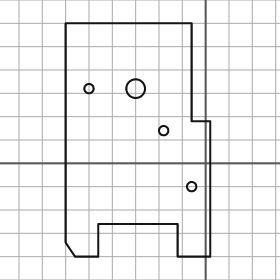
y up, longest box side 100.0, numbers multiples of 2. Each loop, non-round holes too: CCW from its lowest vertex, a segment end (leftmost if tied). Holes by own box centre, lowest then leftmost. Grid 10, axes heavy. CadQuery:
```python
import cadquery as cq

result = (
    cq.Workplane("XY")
    .moveTo(-56.0, -40.0)
    .lineTo(-46.0, -40.0)
    .lineTo(-46.0, -26.0)
    .lineTo(-12.0, -26.0)
    .lineTo(-12.0, -40.0)
    .lineTo(2.0, -40.0)
    .lineTo(2.0, 18.0)
    .lineTo(-6.0, 18.0)
    .lineTo(-6.0, 60.0)
    .lineTo(-60.0, 60.0)
    .lineTo(-60.0, -34.0)
    .close()
    .moveTo(-6.0, -10.0)
    .circle(2.0)
    .moveTo(-18.0, 14.0)
    .circle(2.0)
    .moveTo(-50.0, 32.0)
    .circle(2.0)
    .moveTo(-30.0, 32.0)
    .circle(4.0)
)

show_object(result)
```